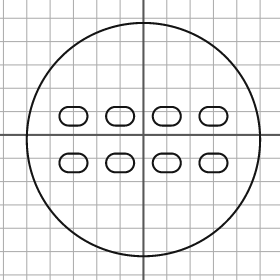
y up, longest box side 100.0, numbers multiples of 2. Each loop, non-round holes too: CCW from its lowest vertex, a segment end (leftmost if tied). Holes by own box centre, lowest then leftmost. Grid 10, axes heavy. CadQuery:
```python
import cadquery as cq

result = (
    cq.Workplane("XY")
    .moveTo(0.0, -2.0)
    .circle(50.0)
    .moveTo(-32.0, -16.0)
    .lineTo(-28.0, -16.0)
    .threePointArc((-24.0, -12.0), (-28.0, -8.0))
    .lineTo(-32.0, -8.0)
    .threePointArc((-36.0, -12.0), (-32.0, -16.0))
    .close()
    .moveTo(-12.0, -16.0)
    .lineTo(-8.0, -16.0)
    .threePointArc((-4.0, -12.0), (-8.0, -8.0))
    .lineTo(-12.0, -8.0)
    .threePointArc((-16.0, -12.0), (-12.0, -16.0))
    .close()
    .moveTo(8.0, -16.0)
    .lineTo(12.0, -16.0)
    .threePointArc((16.0, -12.0), (12.0, -8.0))
    .lineTo(8.0, -8.0)
    .threePointArc((4.0, -12.0), (8.0, -16.0))
    .close()
    .moveTo(28.0, -16.0)
    .lineTo(32.0, -16.0)
    .threePointArc((36.0, -12.0), (32.0, -8.0))
    .lineTo(28.0, -8.0)
    .threePointArc((24.0, -12.0), (28.0, -16.0))
    .close()
    .moveTo(-32.0, 4.0)
    .lineTo(-28.0, 4.0)
    .threePointArc((-24.0, 8.0), (-28.0, 12.0))
    .lineTo(-32.0, 12.0)
    .threePointArc((-36.0, 8.0), (-32.0, 4.0))
    .close()
    .moveTo(-12.0, 4.0)
    .lineTo(-8.0, 4.0)
    .threePointArc((-4.0, 8.0), (-8.0, 12.0))
    .lineTo(-12.0, 12.0)
    .threePointArc((-16.0, 8.0), (-12.0, 4.0))
    .close()
    .moveTo(8.0, 4.0)
    .lineTo(12.0, 4.0)
    .threePointArc((16.0, 8.0), (12.0, 12.0))
    .lineTo(8.0, 12.0)
    .threePointArc((4.0, 8.0), (8.0, 4.0))
    .close()
    .moveTo(28.0, 4.0)
    .lineTo(32.0, 4.0)
    .threePointArc((36.0, 8.0), (32.0, 12.0))
    .lineTo(28.0, 12.0)
    .threePointArc((24.0, 8.0), (28.0, 4.0))
    .close()
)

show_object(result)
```